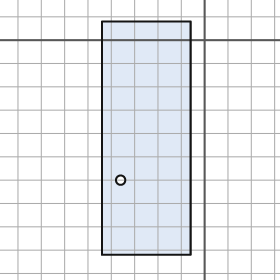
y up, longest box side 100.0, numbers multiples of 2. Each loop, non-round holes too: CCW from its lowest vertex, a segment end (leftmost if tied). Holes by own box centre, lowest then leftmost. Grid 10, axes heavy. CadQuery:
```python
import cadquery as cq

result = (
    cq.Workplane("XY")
    .moveTo(-44.0, -92.0)
    .lineTo(-6.0, -92.0)
    .lineTo(-6.0, 8.0)
    .lineTo(-44.0, 8.0)
    .close()
    .moveTo(-36.0, -60.0)
    .circle(2.0)
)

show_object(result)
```